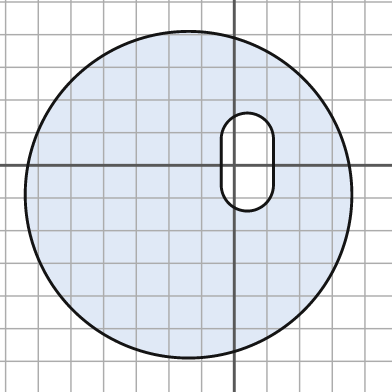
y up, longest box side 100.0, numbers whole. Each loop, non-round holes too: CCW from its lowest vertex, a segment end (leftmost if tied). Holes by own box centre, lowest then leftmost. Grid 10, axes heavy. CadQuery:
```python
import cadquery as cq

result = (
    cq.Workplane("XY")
    .moveTo(-14.0, -9.0)
    .circle(50.0)
    .moveTo(-4.0, -6.0)
    .threePointArc((4.0, -14.0), (12.0, -6.0))
    .lineTo(12.0, 8.0)
    .threePointArc((4.0, 16.0), (-4.0, 8.0))
    .close()
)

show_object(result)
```